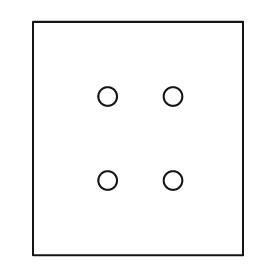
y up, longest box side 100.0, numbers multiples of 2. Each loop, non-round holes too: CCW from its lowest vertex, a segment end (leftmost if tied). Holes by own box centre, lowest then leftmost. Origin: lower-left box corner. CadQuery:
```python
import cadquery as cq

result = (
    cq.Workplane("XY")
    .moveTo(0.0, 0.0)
    .lineTo(90.0, 0.0)
    .lineTo(90.0, 100.0)
    .lineTo(0.0, 100.0)
    .close()
    .moveTo(32.0, 32.0)
    .circle(4.0)
    .moveTo(60.0, 32.0)
    .circle(4.0)
    .moveTo(32.0, 68.0)
    .circle(4.0)
    .moveTo(60.0, 68.0)
    .circle(4.0)
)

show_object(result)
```